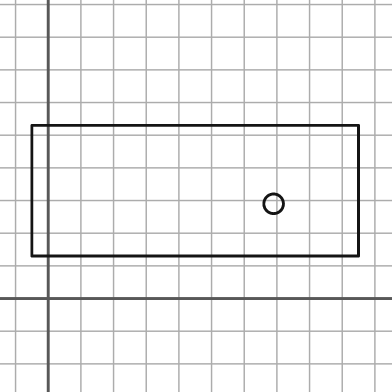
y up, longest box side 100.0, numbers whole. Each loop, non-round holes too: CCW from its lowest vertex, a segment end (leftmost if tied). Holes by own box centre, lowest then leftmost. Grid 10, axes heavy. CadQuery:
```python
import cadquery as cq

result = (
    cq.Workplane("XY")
    .moveTo(-5.0, 13.0)
    .lineTo(95.0, 13.0)
    .lineTo(95.0, 53.0)
    .lineTo(-5.0, 53.0)
    .close()
    .moveTo(69.0, 29.0)
    .circle(3.0)
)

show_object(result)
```